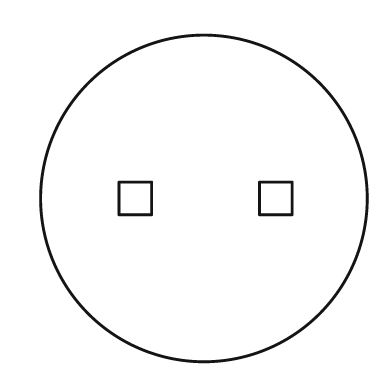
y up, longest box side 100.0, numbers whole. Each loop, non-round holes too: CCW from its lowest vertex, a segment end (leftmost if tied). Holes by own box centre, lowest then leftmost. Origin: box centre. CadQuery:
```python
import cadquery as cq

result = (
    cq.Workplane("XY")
    .moveTo(0.0, 0.0)
    .circle(50.0)
    .moveTo(-26.0, -5.0)
    .lineTo(-16.0, -5.0)
    .lineTo(-16.0, 5.0)
    .lineTo(-26.0, 5.0)
    .close()
    .moveTo(17.0, -5.0)
    .lineTo(27.0, -5.0)
    .lineTo(27.0, 5.0)
    .lineTo(17.0, 5.0)
    .close()
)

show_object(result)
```